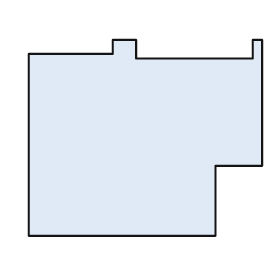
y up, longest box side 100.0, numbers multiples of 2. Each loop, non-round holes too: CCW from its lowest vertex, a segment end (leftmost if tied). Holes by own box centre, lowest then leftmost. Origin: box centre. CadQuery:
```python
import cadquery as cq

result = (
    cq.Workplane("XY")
    .moveTo(-50.0, -42.0)
    .lineTo(30.0, -42.0)
    .lineTo(30.0, -12.0)
    .lineTo(50.0, -12.0)
    .lineTo(50.0, 42.0)
    .lineTo(46.0, 42.0)
    .lineTo(46.0, 34.0)
    .lineTo(-4.0, 34.0)
    .lineTo(-4.0, 42.0)
    .lineTo(-14.0, 42.0)
    .lineTo(-14.0, 36.0)
    .lineTo(-50.0, 36.0)
    .close()
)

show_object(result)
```